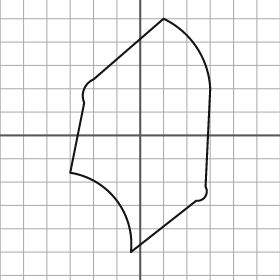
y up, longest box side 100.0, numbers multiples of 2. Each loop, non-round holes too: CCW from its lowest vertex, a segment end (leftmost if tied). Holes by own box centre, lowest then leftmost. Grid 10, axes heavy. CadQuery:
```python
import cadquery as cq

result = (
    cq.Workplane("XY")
    .moveTo(-4.0, -50.0)
    .lineTo(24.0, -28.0)
    .threePointArc((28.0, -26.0), (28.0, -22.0))
    .lineTo(30.0, 20.0)
    .threePointArc((24.0, 38.0), (10.0, 50.0))
    .lineTo(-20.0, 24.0)
    .threePointArc((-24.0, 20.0), (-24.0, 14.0))
    .lineTo(-30.0, -16.0)
    .threePointArc((-10.0, -28.0), (-4.0, -50.0))
    .close()
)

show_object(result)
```